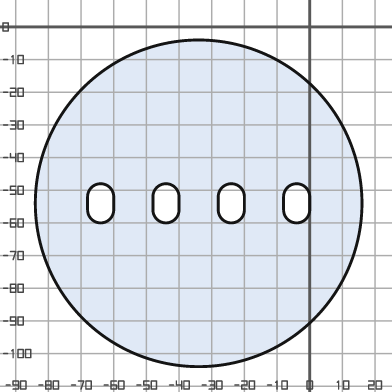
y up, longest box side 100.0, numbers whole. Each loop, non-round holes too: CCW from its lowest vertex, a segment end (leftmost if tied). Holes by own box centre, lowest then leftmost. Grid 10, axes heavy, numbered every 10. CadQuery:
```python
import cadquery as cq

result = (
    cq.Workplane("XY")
    .moveTo(-34.0, -54.0)
    .circle(50.0)
    .moveTo(-68.0, -56.0)
    .threePointArc((-64.0, -60.0), (-60.0, -56.0))
    .lineTo(-60.0, -52.0)
    .threePointArc((-64.0, -48.0), (-68.0, -52.0))
    .close()
    .moveTo(-48.0, -56.0)
    .threePointArc((-44.0, -60.0), (-40.0, -56.0))
    .lineTo(-40.0, -52.0)
    .threePointArc((-44.0, -48.0), (-48.0, -52.0))
    .close()
    .moveTo(-28.0, -56.0)
    .threePointArc((-24.0, -60.0), (-20.0, -56.0))
    .lineTo(-20.0, -52.0)
    .threePointArc((-24.0, -48.0), (-28.0, -52.0))
    .close()
    .moveTo(-8.0, -56.0)
    .threePointArc((-4.0, -60.0), (0.0, -56.0))
    .lineTo(0.0, -52.0)
    .threePointArc((-4.0, -48.0), (-8.0, -52.0))
    .close()
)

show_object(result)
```